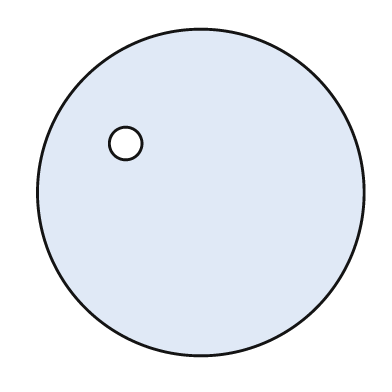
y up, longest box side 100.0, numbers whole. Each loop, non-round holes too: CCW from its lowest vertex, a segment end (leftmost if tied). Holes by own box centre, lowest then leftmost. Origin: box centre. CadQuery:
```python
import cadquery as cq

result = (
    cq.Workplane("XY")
    .moveTo(0.0, 0.0)
    .circle(50.0)
    .moveTo(-23.0, 15.0)
    .circle(5.0)
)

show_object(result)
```